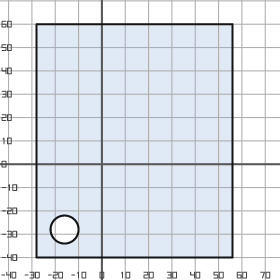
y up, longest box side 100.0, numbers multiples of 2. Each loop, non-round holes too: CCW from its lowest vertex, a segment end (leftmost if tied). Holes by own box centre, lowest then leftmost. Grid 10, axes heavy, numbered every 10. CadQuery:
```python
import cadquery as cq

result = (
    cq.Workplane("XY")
    .moveTo(-28.0, -40.0)
    .lineTo(56.0, -40.0)
    .lineTo(56.0, 60.0)
    .lineTo(-28.0, 60.0)
    .close()
    .moveTo(-16.0, -28.0)
    .circle(6.0)
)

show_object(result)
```